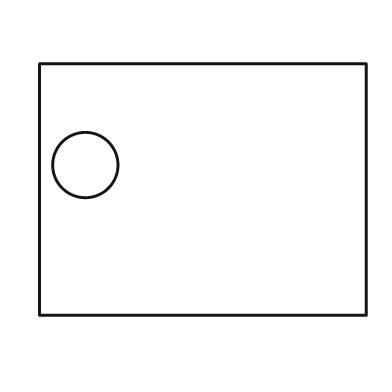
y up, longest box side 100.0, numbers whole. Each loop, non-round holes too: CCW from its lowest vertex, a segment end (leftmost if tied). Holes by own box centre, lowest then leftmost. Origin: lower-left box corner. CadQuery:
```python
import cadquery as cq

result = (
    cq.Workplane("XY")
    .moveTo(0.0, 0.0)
    .lineTo(100.0, 0.0)
    .lineTo(100.0, 77.0)
    .lineTo(0.0, 77.0)
    .close()
    .moveTo(14.0, 46.0)
    .circle(10.0)
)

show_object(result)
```